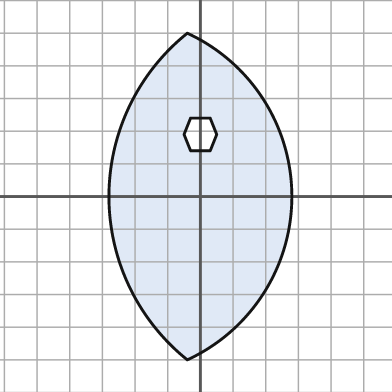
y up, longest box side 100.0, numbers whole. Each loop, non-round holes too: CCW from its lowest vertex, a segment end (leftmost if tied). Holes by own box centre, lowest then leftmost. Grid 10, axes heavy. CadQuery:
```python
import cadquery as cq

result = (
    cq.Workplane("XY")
    .moveTo(-4.0, -50.0)
    .threePointArc((28.0, 0.0), (-4.0, 50.0))
    .threePointArc((-28.0, 0.0), (-4.0, -50.0))
    .close()
    .moveTo(-3.0, 14.0)
    .lineTo(3.0, 14.0)
    .lineTo(5.0, 19.0)
    .lineTo(3.0, 24.0)
    .lineTo(-3.0, 24.0)
    .lineTo(-5.0, 19.0)
    .close()
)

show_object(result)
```